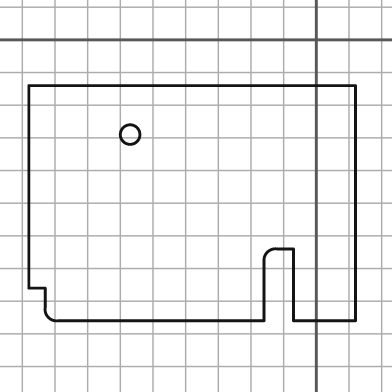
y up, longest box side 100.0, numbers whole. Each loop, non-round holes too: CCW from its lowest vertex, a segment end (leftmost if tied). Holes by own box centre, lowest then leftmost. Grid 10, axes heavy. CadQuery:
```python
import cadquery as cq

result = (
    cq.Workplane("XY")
    .moveTo(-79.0, -86.0)
    .lineTo(-16.0, -86.0)
    .lineTo(-16.0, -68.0)
    .threePointArc((-15.0, -65.0), (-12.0, -64.0))
    .lineTo(-7.0, -64.0)
    .lineTo(-7.0, -86.0)
    .lineTo(12.0, -86.0)
    .lineTo(12.0, -14.0)
    .lineTo(-88.0, -14.0)
    .lineTo(-88.0, -76.0)
    .lineTo(-83.0, -76.0)
    .lineTo(-83.0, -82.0)
    .threePointArc((-82.0, -85.0), (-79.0, -86.0))
    .close()
    .moveTo(-57.0, -29.0)
    .circle(3.0)
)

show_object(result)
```